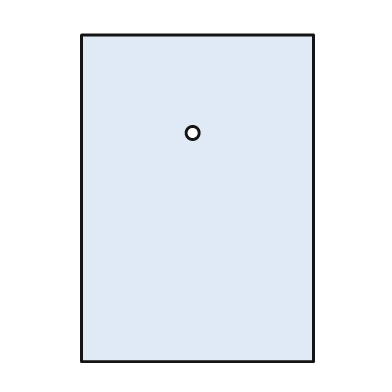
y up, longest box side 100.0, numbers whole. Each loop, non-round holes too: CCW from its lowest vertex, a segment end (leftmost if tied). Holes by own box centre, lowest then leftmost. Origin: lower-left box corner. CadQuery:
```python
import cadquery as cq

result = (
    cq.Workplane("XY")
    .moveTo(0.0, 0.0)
    .lineTo(71.0, 0.0)
    .lineTo(71.0, 100.0)
    .lineTo(0.0, 100.0)
    .close()
    .moveTo(34.0, 70.0)
    .circle(2.0)
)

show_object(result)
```